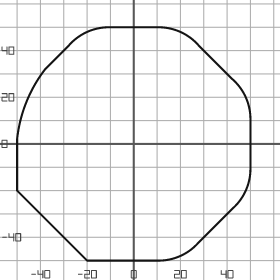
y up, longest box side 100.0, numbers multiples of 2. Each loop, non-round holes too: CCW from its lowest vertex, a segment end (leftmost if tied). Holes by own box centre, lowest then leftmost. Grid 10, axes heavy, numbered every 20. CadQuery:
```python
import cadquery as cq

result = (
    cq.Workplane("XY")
    .moveTo(-20.0, -50.0)
    .lineTo(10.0, -50.0)
    .threePointArc((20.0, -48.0), (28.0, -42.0))
    .lineTo(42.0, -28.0)
    .threePointArc((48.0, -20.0), (50.0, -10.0))
    .lineTo(50.0, 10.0)
    .threePointArc((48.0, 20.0), (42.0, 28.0))
    .lineTo(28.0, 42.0)
    .threePointArc((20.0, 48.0), (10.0, 50.0))
    .lineTo(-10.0, 50.0)
    .threePointArc((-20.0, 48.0), (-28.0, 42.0))
    .lineTo(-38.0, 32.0)
    .threePointArc((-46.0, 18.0), (-50.0, 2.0))
    .lineTo(-50.0, -20.0)
    .close()
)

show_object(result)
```